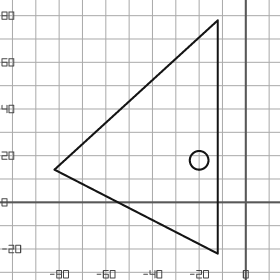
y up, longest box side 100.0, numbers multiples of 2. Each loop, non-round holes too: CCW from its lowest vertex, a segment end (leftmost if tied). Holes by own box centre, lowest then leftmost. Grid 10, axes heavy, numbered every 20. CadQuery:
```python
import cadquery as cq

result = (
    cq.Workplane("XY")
    .moveTo(-12.0, -22.0)
    .lineTo(-12.0, 78.0)
    .lineTo(-82.0, 14.0)
    .close()
    .moveTo(-20.0, 18.0)
    .circle(4.0)
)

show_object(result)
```